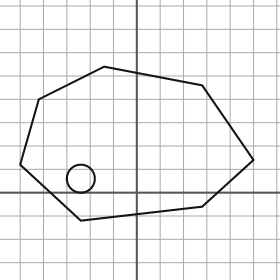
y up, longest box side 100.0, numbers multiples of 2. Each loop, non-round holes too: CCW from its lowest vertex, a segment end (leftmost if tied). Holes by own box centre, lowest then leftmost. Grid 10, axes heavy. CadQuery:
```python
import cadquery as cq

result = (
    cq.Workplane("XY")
    .moveTo(-24.0, -12.0)
    .lineTo(28.0, -6.0)
    .lineTo(50.0, 14.0)
    .lineTo(28.0, 46.0)
    .lineTo(-14.0, 54.0)
    .lineTo(-42.0, 40.0)
    .lineTo(-50.0, 12.0)
    .close()
    .moveTo(-24.0, 6.0)
    .circle(6.0)
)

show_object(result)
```